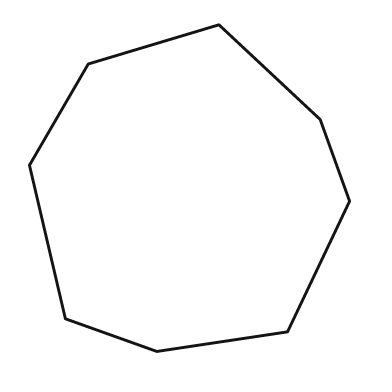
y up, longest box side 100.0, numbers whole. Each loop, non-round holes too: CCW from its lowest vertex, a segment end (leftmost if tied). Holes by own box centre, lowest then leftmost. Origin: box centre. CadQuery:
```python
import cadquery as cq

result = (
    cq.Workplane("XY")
    .moveTo(-10.0, -50.0)
    .lineTo(30.0, -44.0)
    .lineTo(49.0, -4.0)
    .lineTo(40.0, 21.0)
    .lineTo(9.0, 50.0)
    .lineTo(-31.0, 38.0)
    .lineTo(-49.0, 7.0)
    .lineTo(-38.0, -40.0)
    .close()
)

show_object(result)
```